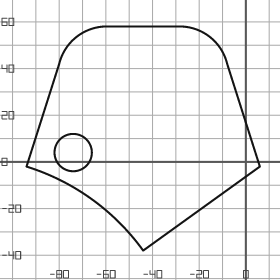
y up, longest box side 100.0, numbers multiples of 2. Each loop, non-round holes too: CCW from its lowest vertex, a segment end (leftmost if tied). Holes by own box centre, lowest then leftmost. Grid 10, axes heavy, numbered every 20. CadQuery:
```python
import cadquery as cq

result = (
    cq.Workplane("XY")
    .moveTo(-44.0, -38.0)
    .lineTo(6.0, -2.0)
    .lineTo(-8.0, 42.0)
    .threePointArc((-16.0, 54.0), (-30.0, 58.0))
    .lineTo(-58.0, 58.0)
    .threePointArc((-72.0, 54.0), (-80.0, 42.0))
    .lineTo(-94.0, -2.0)
    .threePointArc((-66.0, -16.0), (-44.0, -38.0))
    .close()
    .moveTo(-74.0, 4.0)
    .circle(8.0)
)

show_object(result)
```